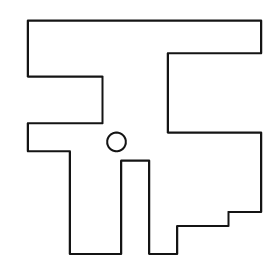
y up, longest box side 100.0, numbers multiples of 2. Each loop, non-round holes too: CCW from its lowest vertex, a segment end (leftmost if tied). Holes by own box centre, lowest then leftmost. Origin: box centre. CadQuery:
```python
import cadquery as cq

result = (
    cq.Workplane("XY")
    .moveTo(-32.0, -50.0)
    .lineTo(-10.0, -50.0)
    .lineTo(-10.0, -10.0)
    .lineTo(2.0, -10.0)
    .lineTo(2.0, -50.0)
    .lineTo(14.0, -50.0)
    .lineTo(14.0, -38.0)
    .lineTo(36.0, -38.0)
    .lineTo(36.0, -32.0)
    .lineTo(50.0, -32.0)
    .lineTo(50.0, 2.0)
    .lineTo(10.0, 2.0)
    .lineTo(10.0, 36.0)
    .lineTo(50.0, 36.0)
    .lineTo(50.0, 50.0)
    .lineTo(-50.0, 50.0)
    .lineTo(-50.0, 26.0)
    .lineTo(-18.0, 26.0)
    .lineTo(-18.0, 6.0)
    .lineTo(-50.0, 6.0)
    .lineTo(-50.0, -6.0)
    .lineTo(-32.0, -6.0)
    .close()
    .moveTo(-12.0, -2.0)
    .circle(4.0)
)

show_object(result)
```